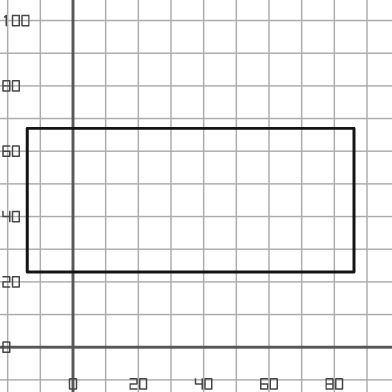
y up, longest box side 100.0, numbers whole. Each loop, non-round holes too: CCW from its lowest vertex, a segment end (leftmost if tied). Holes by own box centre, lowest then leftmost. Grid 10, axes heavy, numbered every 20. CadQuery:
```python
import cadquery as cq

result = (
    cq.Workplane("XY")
    .moveTo(-14.0, 23.0)
    .lineTo(86.0, 23.0)
    .lineTo(86.0, 67.0)
    .lineTo(-14.0, 67.0)
    .close()
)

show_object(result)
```